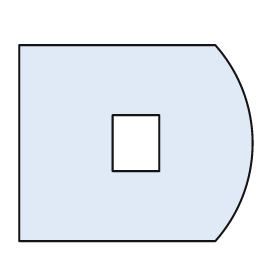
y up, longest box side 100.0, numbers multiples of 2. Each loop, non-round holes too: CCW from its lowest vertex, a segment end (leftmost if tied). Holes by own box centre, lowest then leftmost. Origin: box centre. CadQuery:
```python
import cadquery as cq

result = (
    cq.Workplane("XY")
    .moveTo(-50.0, -42.0)
    .lineTo(34.0, -42.0)
    .threePointArc((50.0, 0.0), (34.0, 42.0))
    .lineTo(-50.0, 42.0)
    .close()
    .moveTo(-10.0, -12.0)
    .lineTo(10.0, -12.0)
    .lineTo(10.0, 12.0)
    .lineTo(-10.0, 12.0)
    .close()
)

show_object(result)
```